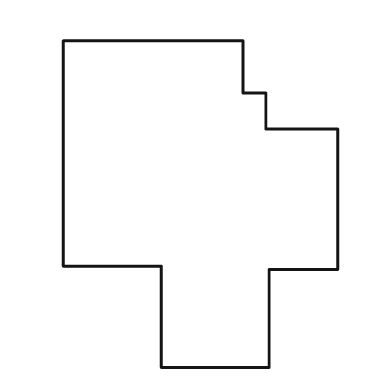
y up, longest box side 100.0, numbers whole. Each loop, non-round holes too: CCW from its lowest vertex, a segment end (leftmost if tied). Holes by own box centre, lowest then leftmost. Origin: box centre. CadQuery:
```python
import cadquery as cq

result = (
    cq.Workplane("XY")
    .moveTo(-12.0, -50.0)
    .lineTo(21.0, -50.0)
    .lineTo(21.0, -20.0)
    .lineTo(42.0, -20.0)
    .lineTo(42.0, 23.0)
    .lineTo(20.0, 23.0)
    .lineTo(20.0, 34.0)
    .lineTo(13.0, 34.0)
    .lineTo(13.0, 50.0)
    .lineTo(-42.0, 50.0)
    .lineTo(-42.0, -19.0)
    .lineTo(-12.0, -19.0)
    .close()
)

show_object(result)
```